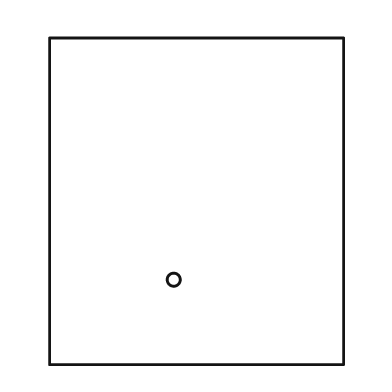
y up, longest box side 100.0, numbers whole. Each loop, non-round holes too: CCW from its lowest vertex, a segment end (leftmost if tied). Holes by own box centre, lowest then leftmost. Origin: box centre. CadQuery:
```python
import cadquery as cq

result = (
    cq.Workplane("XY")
    .moveTo(-45.0, -50.0)
    .lineTo(45.0, -50.0)
    .lineTo(45.0, 50.0)
    .lineTo(-45.0, 50.0)
    .close()
    .moveTo(-7.0, -24.0)
    .circle(2.0)
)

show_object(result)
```